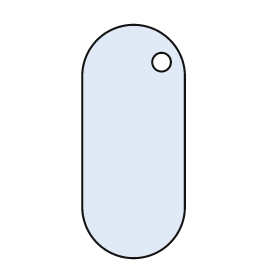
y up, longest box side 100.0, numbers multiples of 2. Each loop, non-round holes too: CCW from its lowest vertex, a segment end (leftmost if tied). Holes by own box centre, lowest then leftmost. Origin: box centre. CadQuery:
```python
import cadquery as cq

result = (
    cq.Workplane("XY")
    .moveTo(-22.0, -28.0)
    .threePointArc((0.0, -50.0), (22.0, -28.0))
    .lineTo(22.0, 28.0)
    .threePointArc((0.0, 50.0), (-22.0, 28.0))
    .close()
    .moveTo(12.0, 34.0)
    .circle(4.0)
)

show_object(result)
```